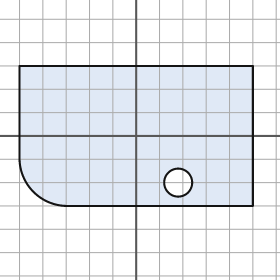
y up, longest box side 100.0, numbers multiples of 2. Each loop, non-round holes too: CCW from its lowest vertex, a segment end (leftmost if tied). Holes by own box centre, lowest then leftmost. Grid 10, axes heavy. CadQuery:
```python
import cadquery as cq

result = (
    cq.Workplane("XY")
    .moveTo(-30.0, -30.0)
    .lineTo(50.0, -30.0)
    .lineTo(50.0, 30.0)
    .lineTo(-50.0, 30.0)
    .lineTo(-50.0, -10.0)
    .threePointArc((-44.0, -24.0), (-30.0, -30.0))
    .close()
    .moveTo(18.0, -20.0)
    .circle(6.0)
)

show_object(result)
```